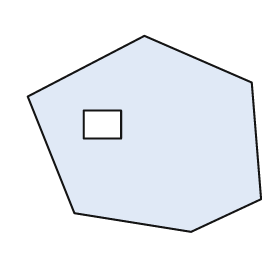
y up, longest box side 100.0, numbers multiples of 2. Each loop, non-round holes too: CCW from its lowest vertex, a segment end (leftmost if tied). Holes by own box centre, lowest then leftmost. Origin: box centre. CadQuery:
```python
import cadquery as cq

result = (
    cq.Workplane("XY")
    .moveTo(20.0, -42.0)
    .lineTo(50.0, -28.0)
    .lineTo(46.0, 22.0)
    .lineTo(0.0, 42.0)
    .lineTo(-50.0, 16.0)
    .lineTo(-30.0, -34.0)
    .close()
    .moveTo(-26.0, -2.0)
    .lineTo(-10.0, -2.0)
    .lineTo(-10.0, 10.0)
    .lineTo(-26.0, 10.0)
    .close()
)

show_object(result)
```